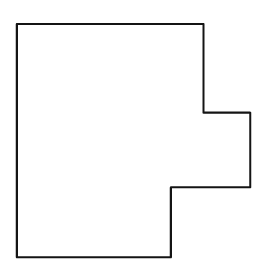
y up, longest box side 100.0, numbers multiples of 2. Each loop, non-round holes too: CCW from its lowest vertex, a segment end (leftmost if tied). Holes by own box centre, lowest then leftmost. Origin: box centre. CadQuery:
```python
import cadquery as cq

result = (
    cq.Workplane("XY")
    .moveTo(-50.0, -50.0)
    .lineTo(16.0, -50.0)
    .lineTo(16.0, -20.0)
    .lineTo(50.0, -20.0)
    .lineTo(50.0, 12.0)
    .lineTo(30.0, 12.0)
    .lineTo(30.0, 50.0)
    .lineTo(-50.0, 50.0)
    .close()
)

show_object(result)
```